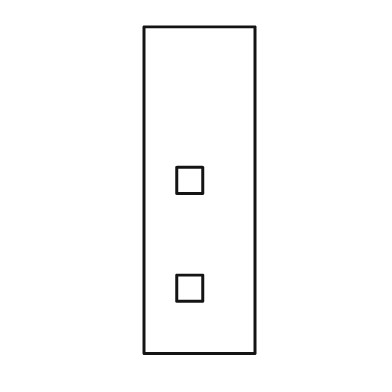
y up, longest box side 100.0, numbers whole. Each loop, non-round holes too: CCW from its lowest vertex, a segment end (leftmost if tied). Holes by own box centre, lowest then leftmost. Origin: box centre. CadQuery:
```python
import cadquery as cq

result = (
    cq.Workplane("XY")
    .moveTo(-17.0, -50.0)
    .lineTo(17.0, -50.0)
    .lineTo(17.0, 50.0)
    .lineTo(-17.0, 50.0)
    .close()
    .moveTo(-7.0, -34.0)
    .lineTo(1.0, -34.0)
    .lineTo(1.0, -26.0)
    .lineTo(-7.0, -26.0)
    .close()
    .moveTo(-7.0, -1.0)
    .lineTo(1.0, -1.0)
    .lineTo(1.0, 7.0)
    .lineTo(-7.0, 7.0)
    .close()
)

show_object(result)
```